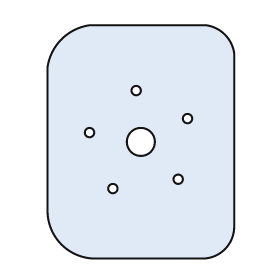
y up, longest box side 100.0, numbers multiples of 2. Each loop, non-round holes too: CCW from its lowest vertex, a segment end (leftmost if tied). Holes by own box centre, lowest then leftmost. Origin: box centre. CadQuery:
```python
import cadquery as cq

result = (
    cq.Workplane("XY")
    .moveTo(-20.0, -50.0)
    .lineTo(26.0, -50.0)
    .threePointArc((36.0, -46.0), (40.0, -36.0))
    .lineTo(40.0, 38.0)
    .threePointArc((36.0, 46.0), (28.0, 50.0))
    .lineTo(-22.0, 50.0)
    .threePointArc((-34.0, 44.0), (-40.0, 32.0))
    .lineTo(-40.0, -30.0)
    .threePointArc((-34.0, -44.0), (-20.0, -50.0))
    .close()
    .moveTo(-12.0, -20.0)
    .circle(2.0)
    .moveTo(16.0, -16.0)
    .circle(2.0)
    .moveTo(0.0, 0.0)
    .circle(6.0)
    .moveTo(-22.0, 4.0)
    .circle(2.0)
    .moveTo(20.0, 10.0)
    .circle(2.0)
    .moveTo(-2.0, 22.0)
    .circle(2.0)
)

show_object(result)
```